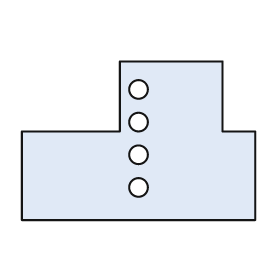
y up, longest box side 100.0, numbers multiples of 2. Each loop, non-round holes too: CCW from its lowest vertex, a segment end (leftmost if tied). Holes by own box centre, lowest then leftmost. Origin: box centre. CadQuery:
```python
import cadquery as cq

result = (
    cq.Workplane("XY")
    .moveTo(-50.0, -34.0)
    .lineTo(50.0, -34.0)
    .lineTo(50.0, 4.0)
    .lineTo(36.0, 4.0)
    .lineTo(36.0, 34.0)
    .lineTo(-8.0, 34.0)
    .lineTo(-8.0, 4.0)
    .lineTo(-50.0, 4.0)
    .close()
    .moveTo(0.0, -20.0)
    .circle(4.0)
    .moveTo(0.0, -6.0)
    .circle(4.0)
    .moveTo(0.0, 8.0)
    .circle(4.0)
    .moveTo(0.0, 22.0)
    .circle(4.0)
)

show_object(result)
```